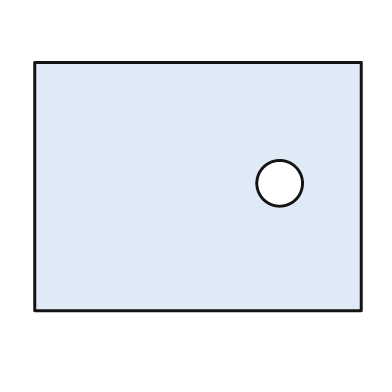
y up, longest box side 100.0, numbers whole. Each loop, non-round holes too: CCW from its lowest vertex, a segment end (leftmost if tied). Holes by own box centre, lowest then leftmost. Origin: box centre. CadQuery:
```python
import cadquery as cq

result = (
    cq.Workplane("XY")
    .moveTo(-50.0, -38.0)
    .lineTo(50.0, -38.0)
    .lineTo(50.0, 38.0)
    .lineTo(-50.0, 38.0)
    .close()
    .moveTo(25.0, 1.0)
    .circle(7.0)
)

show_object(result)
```